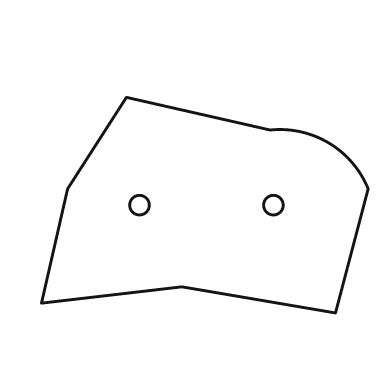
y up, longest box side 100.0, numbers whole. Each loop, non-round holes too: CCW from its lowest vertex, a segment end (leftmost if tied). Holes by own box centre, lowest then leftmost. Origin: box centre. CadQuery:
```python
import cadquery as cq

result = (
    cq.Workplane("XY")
    .moveTo(40.0, -33.0)
    .lineTo(50.0, 5.0)
    .threePointArc((38.0, 19.0), (20.0, 23.0))
    .lineTo(-24.0, 33.0)
    .lineTo(-42.0, 5.0)
    .lineTo(-50.0, -30.0)
    .lineTo(-7.0, -25.0)
    .close()
    .moveTo(-20.0, 0.0)
    .circle(3.0)
    .moveTo(21.0, 0.0)
    .circle(3.0)
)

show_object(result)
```